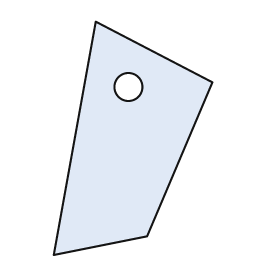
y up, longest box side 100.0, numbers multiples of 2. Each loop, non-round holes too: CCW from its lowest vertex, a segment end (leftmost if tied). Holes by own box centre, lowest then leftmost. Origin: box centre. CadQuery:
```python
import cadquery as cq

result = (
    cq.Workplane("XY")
    .moveTo(-34.0, -50.0)
    .lineTo(6.0, -42.0)
    .lineTo(34.0, 24.0)
    .lineTo(-16.0, 50.0)
    .close()
    .moveTo(-2.0, 22.0)
    .circle(6.0)
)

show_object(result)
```